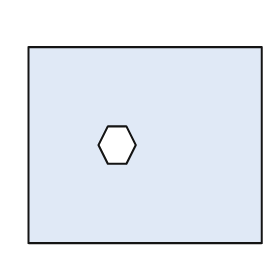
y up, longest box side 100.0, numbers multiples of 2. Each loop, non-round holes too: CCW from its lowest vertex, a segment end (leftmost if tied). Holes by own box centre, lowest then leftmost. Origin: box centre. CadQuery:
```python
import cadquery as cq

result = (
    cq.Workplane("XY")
    .moveTo(-50.0, -42.0)
    .lineTo(50.0, -42.0)
    .lineTo(50.0, 42.0)
    .lineTo(-50.0, 42.0)
    .close()
    .moveTo(-16.0, -8.0)
    .lineTo(-8.0, -8.0)
    .lineTo(-4.0, 0.0)
    .lineTo(-8.0, 8.0)
    .lineTo(-16.0, 8.0)
    .lineTo(-20.0, 0.0)
    .close()
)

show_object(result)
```